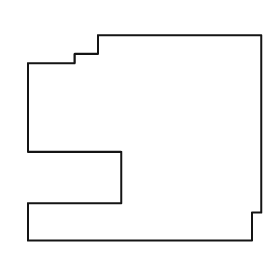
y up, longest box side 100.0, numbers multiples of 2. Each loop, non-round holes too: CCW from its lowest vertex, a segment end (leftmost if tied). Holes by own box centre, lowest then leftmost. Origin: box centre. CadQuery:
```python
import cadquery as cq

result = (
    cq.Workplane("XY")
    .moveTo(-50.0, -44.0)
    .lineTo(46.0, -44.0)
    .lineTo(46.0, -32.0)
    .lineTo(50.0, -32.0)
    .lineTo(50.0, 44.0)
    .lineTo(-20.0, 44.0)
    .lineTo(-20.0, 36.0)
    .lineTo(-30.0, 36.0)
    .lineTo(-30.0, 32.0)
    .lineTo(-50.0, 32.0)
    .lineTo(-50.0, -6.0)
    .lineTo(-10.0, -6.0)
    .lineTo(-10.0, -28.0)
    .lineTo(-50.0, -28.0)
    .close()
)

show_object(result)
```